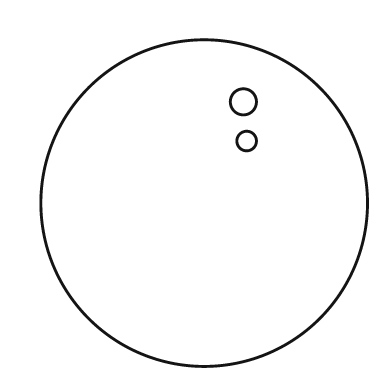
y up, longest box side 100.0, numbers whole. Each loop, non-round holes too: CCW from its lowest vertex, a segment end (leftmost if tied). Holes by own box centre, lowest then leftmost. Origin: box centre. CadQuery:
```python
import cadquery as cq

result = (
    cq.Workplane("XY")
    .moveTo(0.0, 0.0)
    .circle(50.0)
    .moveTo(13.0, 19.0)
    .circle(3.0)
    .moveTo(12.0, 31.0)
    .circle(4.0)
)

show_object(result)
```